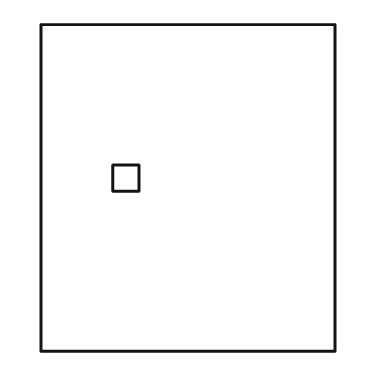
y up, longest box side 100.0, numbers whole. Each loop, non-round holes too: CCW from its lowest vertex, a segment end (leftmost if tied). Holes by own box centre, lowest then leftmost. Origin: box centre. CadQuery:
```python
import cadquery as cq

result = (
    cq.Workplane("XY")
    .moveTo(-45.0, -50.0)
    .lineTo(45.0, -50.0)
    .lineTo(45.0, 50.0)
    .lineTo(-45.0, 50.0)
    .close()
    .moveTo(-23.0, -1.0)
    .lineTo(-15.0, -1.0)
    .lineTo(-15.0, 7.0)
    .lineTo(-23.0, 7.0)
    .close()
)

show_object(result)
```